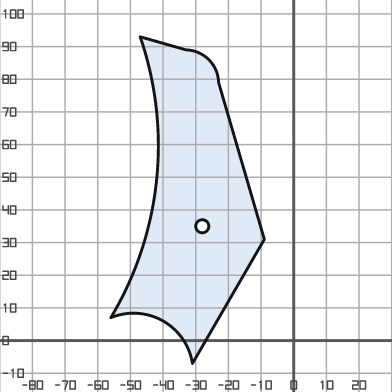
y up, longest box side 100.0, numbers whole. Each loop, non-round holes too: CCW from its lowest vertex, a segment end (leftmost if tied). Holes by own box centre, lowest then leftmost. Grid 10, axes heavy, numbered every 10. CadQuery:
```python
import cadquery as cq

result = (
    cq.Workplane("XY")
    .moveTo(-31.0, -7.0)
    .lineTo(-9.0, 31.0)
    .lineTo(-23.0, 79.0)
    .threePointArc((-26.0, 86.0), (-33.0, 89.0))
    .lineTo(-47.0, 93.0)
    .threePointArc((-42.0, 49.0), (-56.0, 7.0))
    .threePointArc((-40.0, 6.0), (-31.0, -7.0))
    .close()
    .moveTo(-28.0, 35.0)
    .circle(2.0)
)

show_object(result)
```